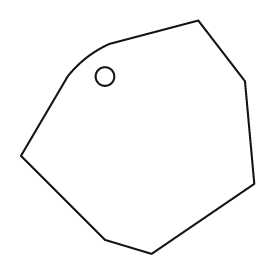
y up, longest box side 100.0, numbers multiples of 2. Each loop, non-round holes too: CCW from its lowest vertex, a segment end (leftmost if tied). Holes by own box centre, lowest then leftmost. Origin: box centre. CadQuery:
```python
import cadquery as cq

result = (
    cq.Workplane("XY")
    .moveTo(6.0, -50.0)
    .lineTo(50.0, -20.0)
    .lineTo(46.0, 24.0)
    .lineTo(26.0, 50.0)
    .lineTo(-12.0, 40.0)
    .threePointArc((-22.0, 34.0), (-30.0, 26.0))
    .lineTo(-50.0, -8.0)
    .lineTo(-14.0, -44.0)
    .close()
    .moveTo(-14.0, 26.0)
    .circle(4.0)
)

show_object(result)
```